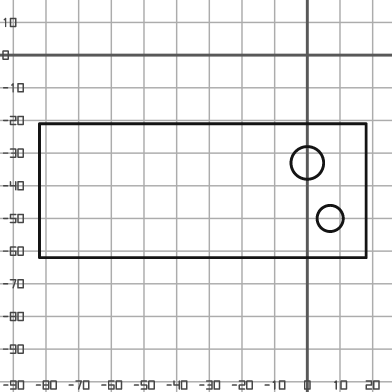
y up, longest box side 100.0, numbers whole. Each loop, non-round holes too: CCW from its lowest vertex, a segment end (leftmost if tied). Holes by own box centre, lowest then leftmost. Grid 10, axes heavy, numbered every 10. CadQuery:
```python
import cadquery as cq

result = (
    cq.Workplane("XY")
    .moveTo(-82.0, -62.0)
    .lineTo(18.0, -62.0)
    .lineTo(18.0, -21.0)
    .lineTo(-82.0, -21.0)
    .close()
    .moveTo(7.0, -50.0)
    .circle(4.0)
    .moveTo(0.0, -33.0)
    .circle(5.0)
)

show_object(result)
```